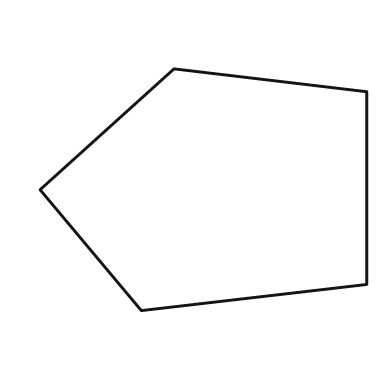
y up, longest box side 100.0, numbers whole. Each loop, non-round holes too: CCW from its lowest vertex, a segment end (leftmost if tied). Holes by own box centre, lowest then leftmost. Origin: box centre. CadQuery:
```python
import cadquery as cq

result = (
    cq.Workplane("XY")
    .moveTo(-19.0, -37.0)
    .lineTo(50.0, -29.0)
    .lineTo(50.0, 30.0)
    .lineTo(-9.0, 37.0)
    .lineTo(-50.0, 0.0)
    .close()
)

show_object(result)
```